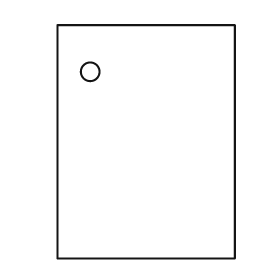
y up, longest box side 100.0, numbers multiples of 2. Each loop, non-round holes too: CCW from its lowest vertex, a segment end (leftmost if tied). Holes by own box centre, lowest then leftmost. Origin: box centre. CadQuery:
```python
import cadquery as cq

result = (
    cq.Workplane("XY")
    .moveTo(-38.0, -50.0)
    .lineTo(38.0, -50.0)
    .lineTo(38.0, 50.0)
    .lineTo(-38.0, 50.0)
    .close()
    .moveTo(-24.0, 30.0)
    .circle(4.0)
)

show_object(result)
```